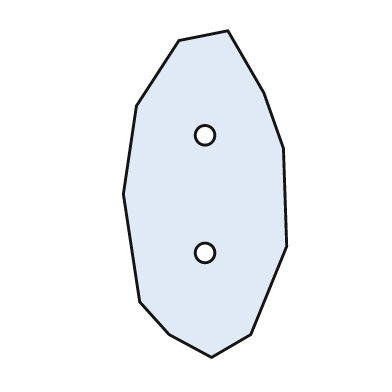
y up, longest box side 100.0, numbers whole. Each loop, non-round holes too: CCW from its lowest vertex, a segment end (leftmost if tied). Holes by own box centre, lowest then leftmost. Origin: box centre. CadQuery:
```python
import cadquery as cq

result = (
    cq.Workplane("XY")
    .moveTo(2.0, -50.0)
    .lineTo(14.0, -43.0)
    .lineTo(25.0, -16.0)
    .lineTo(24.0, 14.0)
    .lineTo(18.0, 31.0)
    .lineTo(7.0, 50.0)
    .lineTo(-8.0, 47.0)
    .lineTo(-21.0, 27.0)
    .lineTo(-25.0, 0.0)
    .lineTo(-20.0, -33.0)
    .lineTo(-11.0, -43.0)
    .close()
    .moveTo(0.0, -18.0)
    .circle(3.0)
    .moveTo(0.0, 18.0)
    .circle(3.0)
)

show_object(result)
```